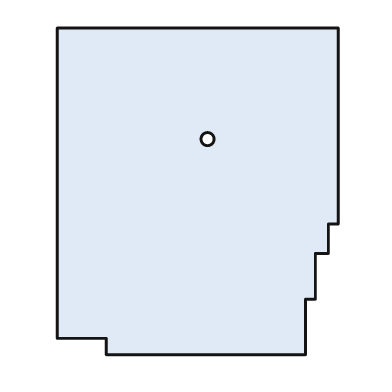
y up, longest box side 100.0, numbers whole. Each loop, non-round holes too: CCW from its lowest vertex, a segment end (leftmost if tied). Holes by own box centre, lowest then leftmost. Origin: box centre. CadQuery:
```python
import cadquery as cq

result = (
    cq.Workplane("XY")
    .moveTo(-28.0, -50.0)
    .lineTo(33.0, -50.0)
    .lineTo(33.0, -33.0)
    .lineTo(36.0, -33.0)
    .lineTo(36.0, -19.0)
    .lineTo(40.0, -19.0)
    .lineTo(40.0, -10.0)
    .lineTo(43.0, -10.0)
    .lineTo(43.0, 50.0)
    .lineTo(-43.0, 50.0)
    .lineTo(-43.0, -45.0)
    .lineTo(-28.0, -45.0)
    .close()
    .moveTo(3.0, 16.0)
    .circle(2.0)
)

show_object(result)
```